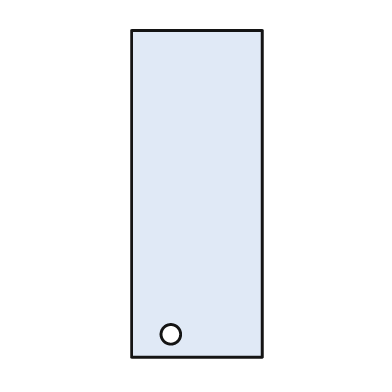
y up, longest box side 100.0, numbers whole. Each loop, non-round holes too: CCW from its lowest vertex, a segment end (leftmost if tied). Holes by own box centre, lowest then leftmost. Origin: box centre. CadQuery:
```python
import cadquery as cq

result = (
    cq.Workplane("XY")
    .moveTo(-20.0, -50.0)
    .lineTo(20.0, -50.0)
    .lineTo(20.0, 50.0)
    .lineTo(-20.0, 50.0)
    .close()
    .moveTo(-8.0, -43.0)
    .circle(3.0)
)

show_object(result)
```